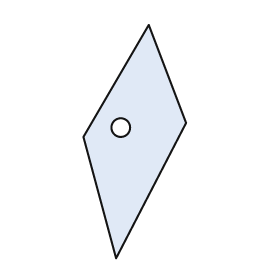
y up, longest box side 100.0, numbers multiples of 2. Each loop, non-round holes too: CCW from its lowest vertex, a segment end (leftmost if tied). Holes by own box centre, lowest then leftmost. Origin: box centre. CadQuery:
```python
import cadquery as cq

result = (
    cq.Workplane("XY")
    .moveTo(-8.0, -50.0)
    .lineTo(22.0, 8.0)
    .lineTo(6.0, 50.0)
    .lineTo(-22.0, 2.0)
    .close()
    .moveTo(-6.0, 6.0)
    .circle(4.0)
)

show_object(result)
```